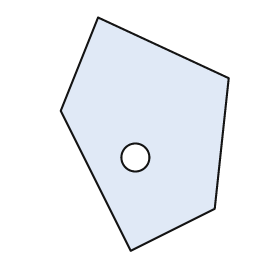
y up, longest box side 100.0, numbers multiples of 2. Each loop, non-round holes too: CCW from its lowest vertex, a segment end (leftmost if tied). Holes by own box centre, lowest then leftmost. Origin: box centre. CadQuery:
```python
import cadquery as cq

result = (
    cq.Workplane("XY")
    .moveTo(-6.0, -50.0)
    .lineTo(30.0, -32.0)
    .lineTo(36.0, 24.0)
    .lineTo(-20.0, 50.0)
    .lineTo(-36.0, 10.0)
    .close()
    .moveTo(-4.0, -10.0)
    .circle(6.0)
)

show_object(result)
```